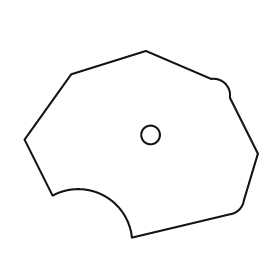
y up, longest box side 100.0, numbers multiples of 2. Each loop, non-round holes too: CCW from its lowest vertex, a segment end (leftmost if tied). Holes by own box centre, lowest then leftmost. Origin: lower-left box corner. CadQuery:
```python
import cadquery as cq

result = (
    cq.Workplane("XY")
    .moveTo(46.0, 0.0)
    .lineTo(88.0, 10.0)
    .threePointArc((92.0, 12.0), (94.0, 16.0))
    .lineTo(100.0, 36.0)
    .lineTo(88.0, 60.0)
    .threePointArc((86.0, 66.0), (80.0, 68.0))
    .lineTo(52.0, 80.0)
    .lineTo(20.0, 70.0)
    .lineTo(0.0, 42.0)
    .lineTo(12.0, 18.0)
    .threePointArc((34.0, 18.0), (46.0, 0.0))
    .close()
    .moveTo(54.0, 44.0)
    .circle(4.0)
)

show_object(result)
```